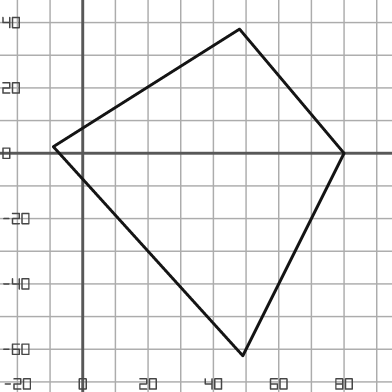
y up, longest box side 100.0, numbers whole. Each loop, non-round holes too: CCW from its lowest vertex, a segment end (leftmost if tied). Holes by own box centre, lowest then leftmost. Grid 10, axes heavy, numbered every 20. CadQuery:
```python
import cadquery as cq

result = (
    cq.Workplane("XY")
    .moveTo(49.0, -62.0)
    .lineTo(80.0, 0.0)
    .lineTo(48.0, 38.0)
    .lineTo(-9.0, 2.0)
    .close()
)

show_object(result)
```